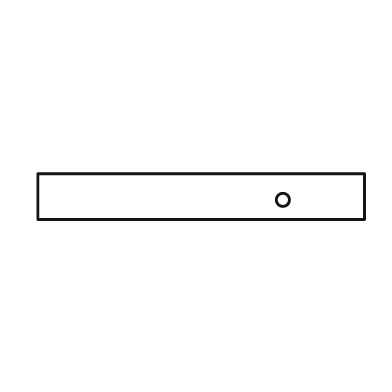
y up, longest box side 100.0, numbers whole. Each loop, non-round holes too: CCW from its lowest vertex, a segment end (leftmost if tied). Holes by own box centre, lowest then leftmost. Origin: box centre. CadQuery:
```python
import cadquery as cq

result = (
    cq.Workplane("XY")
    .moveTo(-50.0, -7.0)
    .lineTo(50.0, -7.0)
    .lineTo(50.0, 7.0)
    .lineTo(-50.0, 7.0)
    .close()
    .moveTo(25.0, -1.0)
    .circle(2.0)
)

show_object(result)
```